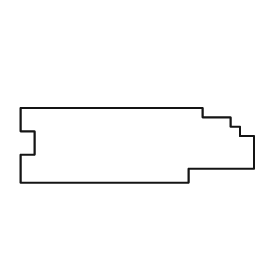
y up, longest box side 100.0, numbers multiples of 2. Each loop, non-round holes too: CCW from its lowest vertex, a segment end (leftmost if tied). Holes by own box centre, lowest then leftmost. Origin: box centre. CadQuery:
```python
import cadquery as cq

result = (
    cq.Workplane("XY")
    .moveTo(-50.0, -16.0)
    .lineTo(22.0, -16.0)
    .lineTo(22.0, -10.0)
    .lineTo(50.0, -10.0)
    .lineTo(50.0, 4.0)
    .lineTo(44.0, 4.0)
    .lineTo(44.0, 8.0)
    .lineTo(40.0, 8.0)
    .lineTo(40.0, 12.0)
    .lineTo(28.0, 12.0)
    .lineTo(28.0, 16.0)
    .lineTo(-50.0, 16.0)
    .lineTo(-50.0, 6.0)
    .lineTo(-44.0, 6.0)
    .lineTo(-44.0, -4.0)
    .lineTo(-50.0, -4.0)
    .close()
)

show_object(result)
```